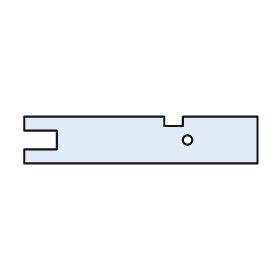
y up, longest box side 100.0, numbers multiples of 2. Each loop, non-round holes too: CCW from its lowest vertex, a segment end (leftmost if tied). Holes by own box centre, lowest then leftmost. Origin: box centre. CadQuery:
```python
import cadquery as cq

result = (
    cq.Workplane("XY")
    .moveTo(-50.0, -10.0)
    .lineTo(50.0, -10.0)
    .lineTo(50.0, 10.0)
    .lineTo(18.0, 10.0)
    .lineTo(18.0, 6.0)
    .lineTo(10.0, 6.0)
    .lineTo(10.0, 10.0)
    .lineTo(-50.0, 10.0)
    .lineTo(-50.0, 4.0)
    .lineTo(-36.0, 4.0)
    .lineTo(-36.0, -4.0)
    .lineTo(-50.0, -4.0)
    .close()
    .moveTo(20.0, 0.0)
    .circle(2.0)
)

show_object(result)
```